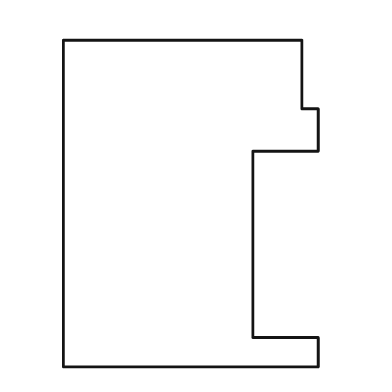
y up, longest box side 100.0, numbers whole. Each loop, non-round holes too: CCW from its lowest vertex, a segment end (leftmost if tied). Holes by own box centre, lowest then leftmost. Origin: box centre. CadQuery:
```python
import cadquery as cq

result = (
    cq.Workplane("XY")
    .moveTo(-39.0, -50.0)
    .lineTo(39.0, -50.0)
    .lineTo(39.0, -41.0)
    .lineTo(19.0, -41.0)
    .lineTo(19.0, 16.0)
    .lineTo(39.0, 16.0)
    .lineTo(39.0, 29.0)
    .lineTo(34.0, 29.0)
    .lineTo(34.0, 50.0)
    .lineTo(-39.0, 50.0)
    .close()
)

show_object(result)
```